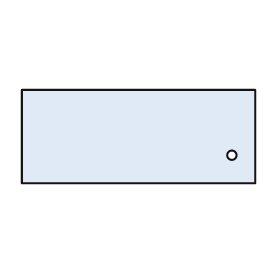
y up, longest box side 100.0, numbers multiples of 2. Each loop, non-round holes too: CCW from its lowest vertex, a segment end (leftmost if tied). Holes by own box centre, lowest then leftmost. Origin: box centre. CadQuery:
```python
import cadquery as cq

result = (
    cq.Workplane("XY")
    .moveTo(-50.0, -20.0)
    .lineTo(50.0, -20.0)
    .lineTo(50.0, 20.0)
    .lineTo(-50.0, 20.0)
    .close()
    .moveTo(40.0, -8.0)
    .circle(2.0)
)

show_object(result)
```